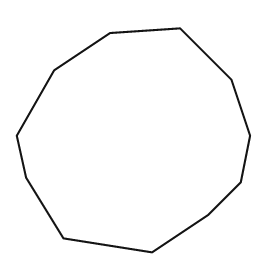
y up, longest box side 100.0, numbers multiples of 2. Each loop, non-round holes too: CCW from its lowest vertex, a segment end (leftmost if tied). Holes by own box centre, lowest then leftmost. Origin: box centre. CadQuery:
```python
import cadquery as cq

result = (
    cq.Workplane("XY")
    .moveTo(8.0, -48.0)
    .lineTo(32.0, -32.0)
    .lineTo(46.0, -18.0)
    .lineTo(50.0, 2.0)
    .lineTo(42.0, 26.0)
    .lineTo(20.0, 48.0)
    .lineTo(-10.0, 46.0)
    .lineTo(-34.0, 30.0)
    .lineTo(-50.0, 2.0)
    .lineTo(-46.0, -16.0)
    .lineTo(-30.0, -42.0)
    .close()
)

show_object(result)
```